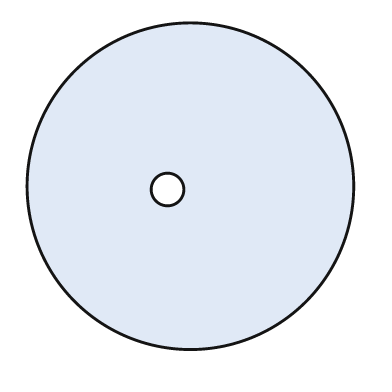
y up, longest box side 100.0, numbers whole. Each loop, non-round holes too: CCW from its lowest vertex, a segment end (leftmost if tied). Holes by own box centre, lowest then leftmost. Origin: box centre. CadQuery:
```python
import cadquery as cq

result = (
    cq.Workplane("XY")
    .moveTo(0.0, 0.0)
    .circle(50.0)
    .moveTo(-7.0, -1.0)
    .circle(5.0)
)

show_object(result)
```